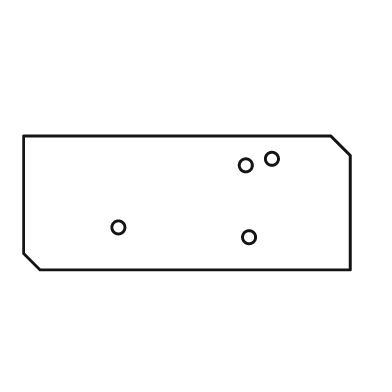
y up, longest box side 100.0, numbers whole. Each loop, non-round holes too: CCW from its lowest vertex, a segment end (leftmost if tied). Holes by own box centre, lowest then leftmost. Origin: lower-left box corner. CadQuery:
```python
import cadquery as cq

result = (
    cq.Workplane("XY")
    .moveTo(5.0, 0.0)
    .lineTo(100.0, 0.0)
    .lineTo(100.0, 35.0)
    .lineTo(94.0, 41.0)
    .lineTo(0.0, 41.0)
    .lineTo(0.0, 5.0)
    .close()
    .moveTo(69.0, 10.0)
    .circle(2.0)
    .moveTo(29.0, 13.0)
    .circle(2.0)
    .moveTo(68.0, 32.0)
    .circle(2.0)
    .moveTo(76.0, 34.0)
    .circle(2.0)
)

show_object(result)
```